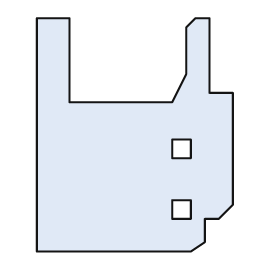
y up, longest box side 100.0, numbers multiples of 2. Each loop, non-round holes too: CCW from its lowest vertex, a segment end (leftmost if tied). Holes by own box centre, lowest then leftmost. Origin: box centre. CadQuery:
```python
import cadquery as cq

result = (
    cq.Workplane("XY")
    .moveTo(-42.0, -50.0)
    .lineTo(24.0, -50.0)
    .lineTo(30.0, -46.0)
    .lineTo(30.0, -36.0)
    .lineTo(36.0, -36.0)
    .lineTo(42.0, -30.0)
    .lineTo(42.0, 18.0)
    .lineTo(32.0, 18.0)
    .lineTo(32.0, 50.0)
    .lineTo(26.0, 50.0)
    .lineTo(22.0, 46.0)
    .lineTo(22.0, 26.0)
    .lineTo(16.0, 14.0)
    .lineTo(-28.0, 14.0)
    .lineTo(-28.0, 50.0)
    .lineTo(-42.0, 50.0)
    .close()
    .moveTo(16.0, -36.0)
    .lineTo(24.0, -36.0)
    .lineTo(24.0, -28.0)
    .lineTo(16.0, -28.0)
    .close()
    .moveTo(16.0, -10.0)
    .lineTo(24.0, -10.0)
    .lineTo(24.0, -2.0)
    .lineTo(16.0, -2.0)
    .close()
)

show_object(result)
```